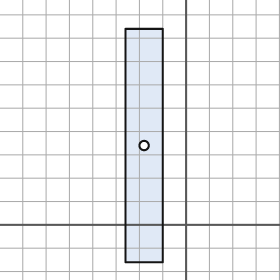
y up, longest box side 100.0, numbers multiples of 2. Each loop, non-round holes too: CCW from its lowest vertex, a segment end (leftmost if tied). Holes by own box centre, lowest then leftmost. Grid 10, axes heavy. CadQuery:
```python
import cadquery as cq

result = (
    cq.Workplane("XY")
    .moveTo(-26.0, -16.0)
    .lineTo(-10.0, -16.0)
    .lineTo(-10.0, 84.0)
    .lineTo(-26.0, 84.0)
    .close()
    .moveTo(-18.0, 34.0)
    .circle(2.0)
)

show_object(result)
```